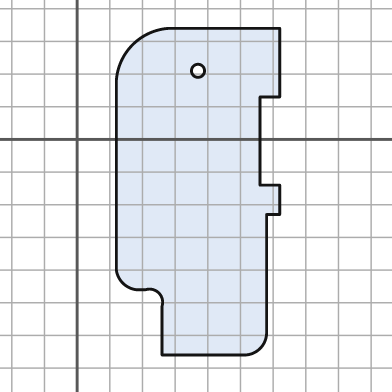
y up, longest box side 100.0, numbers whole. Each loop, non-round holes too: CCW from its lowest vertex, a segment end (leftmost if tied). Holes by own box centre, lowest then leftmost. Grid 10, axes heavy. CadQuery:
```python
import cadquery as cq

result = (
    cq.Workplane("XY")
    .moveTo(26.0, -66.0)
    .lineTo(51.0, -66.0)
    .threePointArc((56.0, -64.0), (58.0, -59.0))
    .lineTo(58.0, -23.0)
    .lineTo(62.0, -23.0)
    .lineTo(62.0, -14.0)
    .lineTo(56.0, -14.0)
    .lineTo(56.0, 13.0)
    .lineTo(62.0, 13.0)
    .lineTo(62.0, 34.0)
    .lineTo(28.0, 34.0)
    .threePointArc((17.0, 29.0), (12.0, 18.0))
    .lineTo(12.0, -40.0)
    .threePointArc((14.0, -44.0), (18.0, -46.0))
    .lineTo(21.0, -46.0)
    .threePointArc((25.0, -47.0), (26.0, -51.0))
    .close()
    .moveTo(37.0, 21.0)
    .circle(2.0)
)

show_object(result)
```